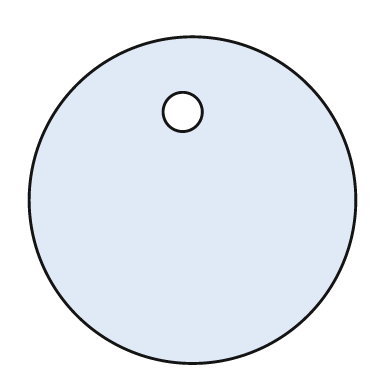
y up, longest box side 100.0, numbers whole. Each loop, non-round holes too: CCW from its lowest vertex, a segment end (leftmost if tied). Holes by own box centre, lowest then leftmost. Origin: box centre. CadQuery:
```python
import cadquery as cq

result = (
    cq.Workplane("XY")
    .moveTo(0.0, 0.0)
    .circle(50.0)
    .moveTo(-3.0, 27.0)
    .circle(6.0)
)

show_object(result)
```